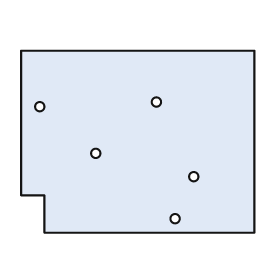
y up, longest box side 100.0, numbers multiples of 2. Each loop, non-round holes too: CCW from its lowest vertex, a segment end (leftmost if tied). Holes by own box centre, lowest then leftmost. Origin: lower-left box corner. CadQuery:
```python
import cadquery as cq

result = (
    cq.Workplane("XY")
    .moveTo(10.0, 0.0)
    .lineTo(100.0, 0.0)
    .lineTo(100.0, 78.0)
    .lineTo(0.0, 78.0)
    .lineTo(0.0, 16.0)
    .lineTo(10.0, 16.0)
    .close()
    .moveTo(66.0, 6.0)
    .circle(2.0)
    .moveTo(74.0, 24.0)
    .circle(2.0)
    .moveTo(32.0, 34.0)
    .circle(2.0)
    .moveTo(8.0, 54.0)
    .circle(2.0)
    .moveTo(58.0, 56.0)
    .circle(2.0)
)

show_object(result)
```